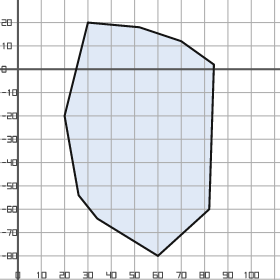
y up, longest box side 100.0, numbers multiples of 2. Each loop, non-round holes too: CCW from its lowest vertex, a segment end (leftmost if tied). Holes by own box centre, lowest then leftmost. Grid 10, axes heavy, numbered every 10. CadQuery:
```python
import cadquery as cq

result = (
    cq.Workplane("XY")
    .moveTo(60.0, -80.0)
    .lineTo(82.0, -60.0)
    .lineTo(84.0, 2.0)
    .lineTo(70.0, 12.0)
    .lineTo(52.0, 18.0)
    .lineTo(30.0, 20.0)
    .lineTo(20.0, -20.0)
    .lineTo(26.0, -54.0)
    .lineTo(34.0, -64.0)
    .close()
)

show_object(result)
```